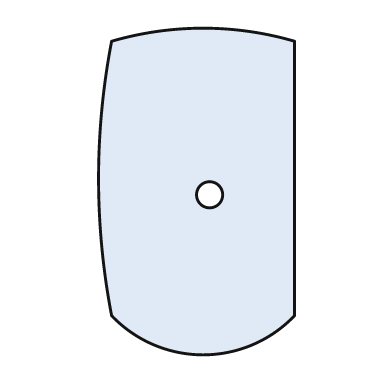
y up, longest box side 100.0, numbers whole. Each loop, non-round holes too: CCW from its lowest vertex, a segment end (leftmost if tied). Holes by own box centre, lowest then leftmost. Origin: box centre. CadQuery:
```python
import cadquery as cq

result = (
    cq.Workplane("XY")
    .moveTo(-26.0, -38.0)
    .threePointArc((2.0, -50.0), (30.0, -38.0))
    .lineTo(30.0, 46.0)
    .threePointArc((2.0, 50.0), (-26.0, 46.0))
    .threePointArc((-30.0, 4.0), (-26.0, -38.0))
    .close()
    .moveTo(4.0, -1.0)
    .circle(4.0)
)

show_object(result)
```